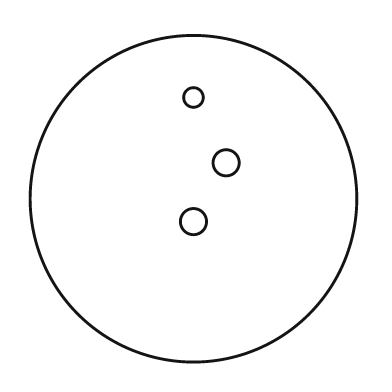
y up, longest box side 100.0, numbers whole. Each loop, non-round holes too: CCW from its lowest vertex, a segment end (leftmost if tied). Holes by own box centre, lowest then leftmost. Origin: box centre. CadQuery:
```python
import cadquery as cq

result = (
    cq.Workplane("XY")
    .moveTo(0.0, 0.0)
    .circle(50.0)
    .moveTo(0.0, -7.0)
    .circle(4.0)
    .moveTo(10.0, 11.0)
    .circle(4.0)
    .moveTo(0.0, 31.0)
    .circle(3.0)
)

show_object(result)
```